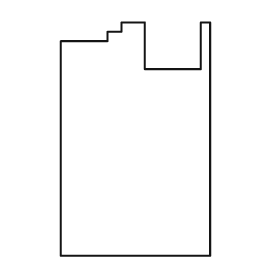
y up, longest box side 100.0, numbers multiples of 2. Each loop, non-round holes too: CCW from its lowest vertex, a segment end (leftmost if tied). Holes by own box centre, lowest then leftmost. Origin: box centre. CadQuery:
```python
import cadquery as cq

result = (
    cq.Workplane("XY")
    .moveTo(-32.0, -50.0)
    .lineTo(32.0, -50.0)
    .lineTo(32.0, 50.0)
    .lineTo(28.0, 50.0)
    .lineTo(28.0, 30.0)
    .lineTo(4.0, 30.0)
    .lineTo(4.0, 50.0)
    .lineTo(-6.0, 50.0)
    .lineTo(-6.0, 46.0)
    .lineTo(-12.0, 46.0)
    .lineTo(-12.0, 42.0)
    .lineTo(-32.0, 42.0)
    .close()
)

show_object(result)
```